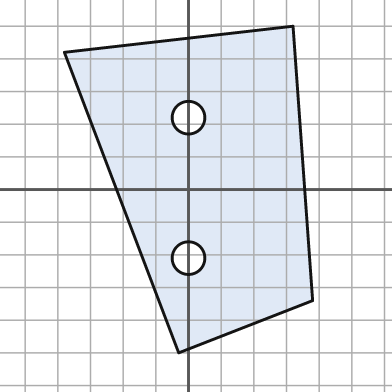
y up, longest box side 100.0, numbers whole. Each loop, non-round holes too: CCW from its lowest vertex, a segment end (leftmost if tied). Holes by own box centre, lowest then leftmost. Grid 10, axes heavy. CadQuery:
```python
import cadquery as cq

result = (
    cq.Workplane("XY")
    .moveTo(-3.0, -50.0)
    .lineTo(38.0, -34.0)
    .lineTo(32.0, 50.0)
    .lineTo(-38.0, 42.0)
    .close()
    .moveTo(0.0, -21.0)
    .circle(5.0)
    .moveTo(0.0, 22.0)
    .circle(5.0)
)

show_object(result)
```